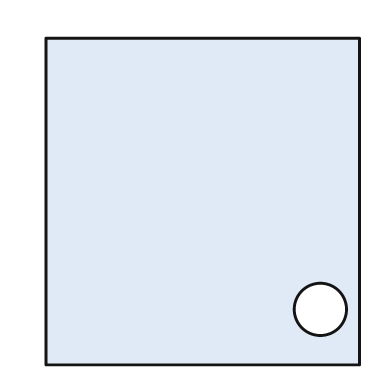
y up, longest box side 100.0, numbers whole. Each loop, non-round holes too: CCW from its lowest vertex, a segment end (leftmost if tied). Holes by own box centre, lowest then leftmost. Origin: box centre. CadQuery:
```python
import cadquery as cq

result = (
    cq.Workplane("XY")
    .moveTo(-48.0, -50.0)
    .lineTo(48.0, -50.0)
    .lineTo(48.0, 50.0)
    .lineTo(-48.0, 50.0)
    .close()
    .moveTo(36.0, -33.0)
    .circle(8.0)
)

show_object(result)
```